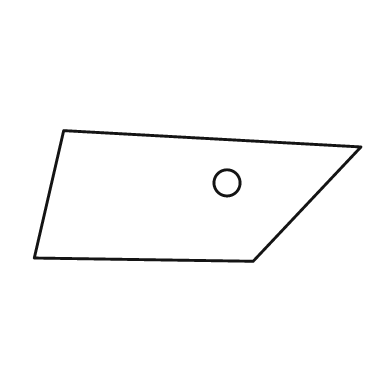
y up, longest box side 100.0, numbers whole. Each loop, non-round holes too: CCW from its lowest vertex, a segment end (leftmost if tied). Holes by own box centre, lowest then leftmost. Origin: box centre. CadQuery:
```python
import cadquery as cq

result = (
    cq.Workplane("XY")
    .moveTo(17.0, -20.0)
    .lineTo(50.0, 15.0)
    .lineTo(-41.0, 20.0)
    .lineTo(-50.0, -19.0)
    .close()
    .moveTo(9.0, 4.0)
    .circle(4.0)
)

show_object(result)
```